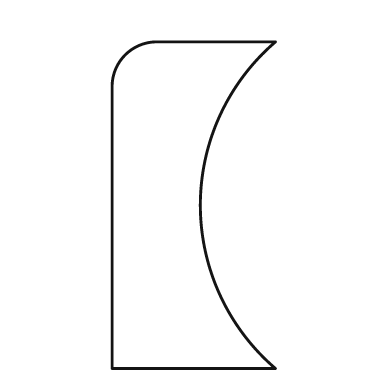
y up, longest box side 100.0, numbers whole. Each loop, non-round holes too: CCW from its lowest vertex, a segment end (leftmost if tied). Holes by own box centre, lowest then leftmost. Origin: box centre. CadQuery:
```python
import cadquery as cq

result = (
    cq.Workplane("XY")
    .moveTo(-25.0, -50.0)
    .lineTo(25.0, -50.0)
    .threePointArc((2.0, 0.0), (25.0, 50.0))
    .lineTo(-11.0, 50.0)
    .threePointArc((-21.0, 46.0), (-25.0, 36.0))
    .close()
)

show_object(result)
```